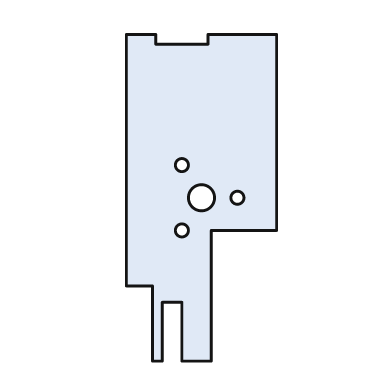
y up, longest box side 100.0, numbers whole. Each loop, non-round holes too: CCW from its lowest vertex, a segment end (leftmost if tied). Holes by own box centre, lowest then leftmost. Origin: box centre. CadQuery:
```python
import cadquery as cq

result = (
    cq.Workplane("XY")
    .moveTo(-15.0, -50.0)
    .lineTo(-12.0, -50.0)
    .lineTo(-12.0, -32.0)
    .lineTo(-6.0, -32.0)
    .lineTo(-6.0, -50.0)
    .lineTo(3.0, -50.0)
    .lineTo(3.0, -10.0)
    .lineTo(23.0, -10.0)
    .lineTo(23.0, 50.0)
    .lineTo(2.0, 50.0)
    .lineTo(2.0, 47.0)
    .lineTo(-14.0, 47.0)
    .lineTo(-14.0, 50.0)
    .lineTo(-23.0, 50.0)
    .lineTo(-23.0, -27.0)
    .lineTo(-15.0, -27.0)
    .close()
    .moveTo(-6.0, -10.0)
    .circle(2.0)
    .moveTo(0.0, 0.0)
    .circle(4.0)
    .moveTo(11.0, 0.0)
    .circle(2.0)
    .moveTo(-6.0, 10.0)
    .circle(2.0)
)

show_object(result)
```